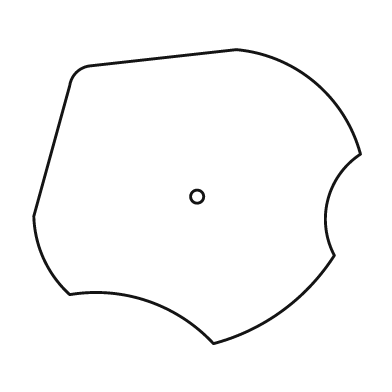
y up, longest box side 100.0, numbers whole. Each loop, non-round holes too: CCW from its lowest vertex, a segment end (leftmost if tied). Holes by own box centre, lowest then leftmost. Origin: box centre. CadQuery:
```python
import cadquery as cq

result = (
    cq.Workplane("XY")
    .moveTo(5.0, -45.0)
    .threePointArc((26.0, -35.0), (42.0, -18.0))
    .threePointArc((40.0, -1.0), (50.0, 13.0))
    .threePointArc((36.0, 35.0), (12.0, 45.0))
    .lineTo(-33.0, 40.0)
    .threePointArc((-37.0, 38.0), (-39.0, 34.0))
    .lineTo(-50.0, -6.0)
    .threePointArc((-47.0, -19.0), (-39.0, -30.0))
    .threePointArc((-15.0, -32.0), (5.0, -45.0))
    .close()
    .moveTo(0.0, 0.0)
    .circle(2.0)
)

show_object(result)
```